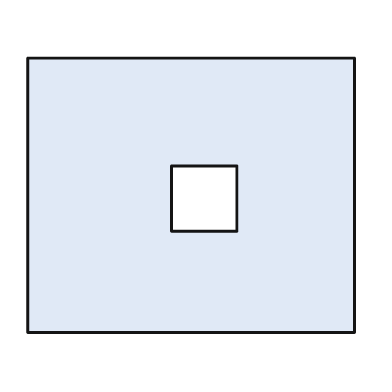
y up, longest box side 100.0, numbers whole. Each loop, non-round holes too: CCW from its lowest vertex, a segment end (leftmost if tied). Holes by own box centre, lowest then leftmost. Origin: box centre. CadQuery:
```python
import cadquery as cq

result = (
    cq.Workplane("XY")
    .moveTo(-50.0, -42.0)
    .lineTo(50.0, -42.0)
    .lineTo(50.0, 42.0)
    .lineTo(-50.0, 42.0)
    .close()
    .moveTo(-6.0, -11.0)
    .lineTo(14.0, -11.0)
    .lineTo(14.0, 9.0)
    .lineTo(-6.0, 9.0)
    .close()
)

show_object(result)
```